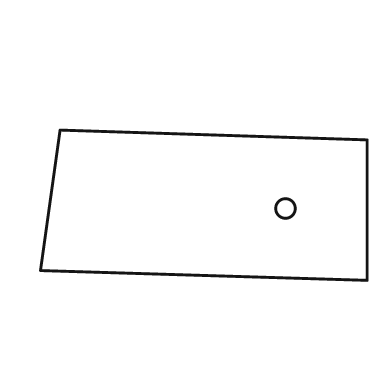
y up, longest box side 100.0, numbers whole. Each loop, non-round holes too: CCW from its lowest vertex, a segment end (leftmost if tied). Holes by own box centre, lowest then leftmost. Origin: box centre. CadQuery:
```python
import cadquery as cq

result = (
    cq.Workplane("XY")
    .moveTo(50.0, -23.0)
    .lineTo(50.0, 20.0)
    .lineTo(-44.0, 23.0)
    .lineTo(-50.0, -20.0)
    .close()
    .moveTo(25.0, -1.0)
    .circle(3.0)
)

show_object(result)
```